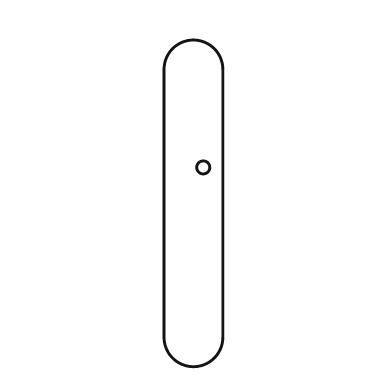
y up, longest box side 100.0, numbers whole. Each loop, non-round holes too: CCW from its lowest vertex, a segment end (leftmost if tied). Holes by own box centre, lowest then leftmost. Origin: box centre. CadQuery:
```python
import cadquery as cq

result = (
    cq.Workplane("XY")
    .moveTo(-9.0, -41.0)
    .threePointArc((0.0, -50.0), (9.0, -41.0))
    .lineTo(9.0, 41.0)
    .threePointArc((0.0, 50.0), (-9.0, 41.0))
    .close()
    .moveTo(3.0, 11.0)
    .circle(2.0)
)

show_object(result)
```